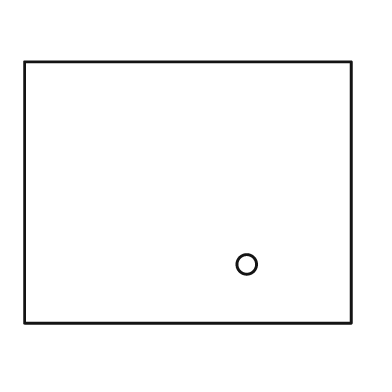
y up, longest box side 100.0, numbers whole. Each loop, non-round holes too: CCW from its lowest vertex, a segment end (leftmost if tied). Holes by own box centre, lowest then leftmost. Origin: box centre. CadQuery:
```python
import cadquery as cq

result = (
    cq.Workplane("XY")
    .moveTo(-50.0, -40.0)
    .lineTo(50.0, -40.0)
    .lineTo(50.0, 40.0)
    .lineTo(-50.0, 40.0)
    .close()
    .moveTo(18.0, -22.0)
    .circle(3.0)
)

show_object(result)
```